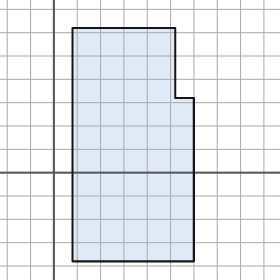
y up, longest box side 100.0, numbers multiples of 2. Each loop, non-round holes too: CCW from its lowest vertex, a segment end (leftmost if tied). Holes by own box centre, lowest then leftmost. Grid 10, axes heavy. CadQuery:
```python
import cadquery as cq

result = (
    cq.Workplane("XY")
    .moveTo(8.0, -38.0)
    .lineTo(60.0, -38.0)
    .lineTo(60.0, 32.0)
    .lineTo(52.0, 32.0)
    .lineTo(52.0, 62.0)
    .lineTo(8.0, 62.0)
    .close()
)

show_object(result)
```